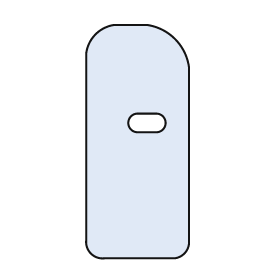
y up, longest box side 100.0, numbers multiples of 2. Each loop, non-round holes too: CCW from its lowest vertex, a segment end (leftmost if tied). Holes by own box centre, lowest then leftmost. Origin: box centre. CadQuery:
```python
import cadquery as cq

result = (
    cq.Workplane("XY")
    .moveTo(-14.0, -50.0)
    .lineTo(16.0, -50.0)
    .threePointArc((20.0, -48.0), (22.0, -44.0))
    .lineTo(22.0, 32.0)
    .threePointArc((16.0, 44.0), (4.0, 50.0))
    .lineTo(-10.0, 50.0)
    .threePointArc((-18.0, 46.0), (-22.0, 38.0))
    .lineTo(-22.0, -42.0)
    .threePointArc((-20.0, -48.0), (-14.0, -50.0))
    .close()
    .moveTo(0.0, 4.0)
    .lineTo(8.0, 4.0)
    .threePointArc((12.0, 8.0), (8.0, 12.0))
    .lineTo(0.0, 12.0)
    .threePointArc((-4.0, 8.0), (0.0, 4.0))
    .close()
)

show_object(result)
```